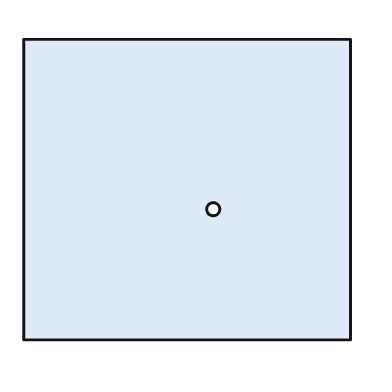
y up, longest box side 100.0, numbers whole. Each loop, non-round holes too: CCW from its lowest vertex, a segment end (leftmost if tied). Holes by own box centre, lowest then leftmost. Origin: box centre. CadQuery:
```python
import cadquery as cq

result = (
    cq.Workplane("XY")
    .moveTo(-50.0, -46.0)
    .lineTo(50.0, -46.0)
    .lineTo(50.0, 46.0)
    .lineTo(-50.0, 46.0)
    .close()
    .moveTo(8.0, -6.0)
    .circle(2.0)
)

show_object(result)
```